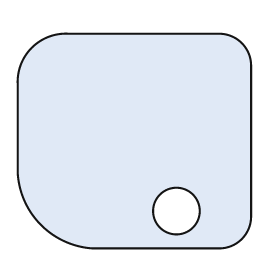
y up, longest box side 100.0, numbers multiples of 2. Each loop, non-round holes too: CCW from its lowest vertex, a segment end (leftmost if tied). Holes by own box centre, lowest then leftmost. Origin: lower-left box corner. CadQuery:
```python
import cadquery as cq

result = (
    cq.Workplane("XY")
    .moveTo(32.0, 0.0)
    .lineTo(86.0, 0.0)
    .threePointArc((96.0, 4.0), (100.0, 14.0))
    .lineTo(100.0, 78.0)
    .threePointArc((96.0, 88.0), (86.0, 92.0))
    .lineTo(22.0, 92.0)
    .threePointArc((6.0, 86.0), (0.0, 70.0))
    .lineTo(0.0, 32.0)
    .threePointArc((10.0, 10.0), (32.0, 0.0))
    .close()
    .moveTo(68.0, 16.0)
    .circle(10.0)
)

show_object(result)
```